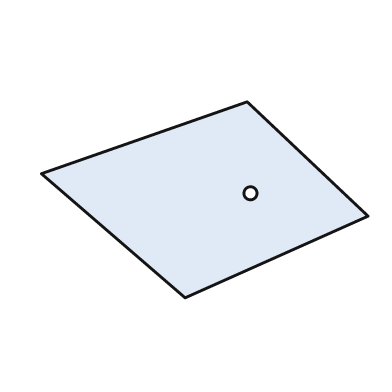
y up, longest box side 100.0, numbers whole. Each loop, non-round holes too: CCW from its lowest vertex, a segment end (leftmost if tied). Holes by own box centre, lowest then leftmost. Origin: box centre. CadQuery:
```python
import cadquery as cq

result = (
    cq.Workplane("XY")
    .moveTo(-6.0, -30.0)
    .lineTo(50.0, -5.0)
    .lineTo(13.0, 30.0)
    .lineTo(-50.0, 8.0)
    .close()
    .moveTo(14.0, 2.0)
    .circle(2.0)
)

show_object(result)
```